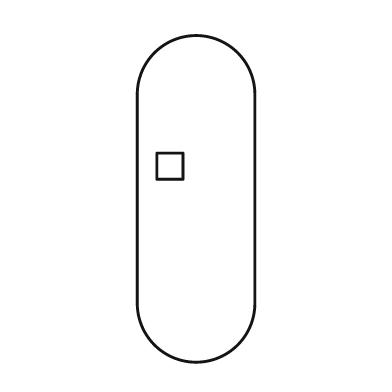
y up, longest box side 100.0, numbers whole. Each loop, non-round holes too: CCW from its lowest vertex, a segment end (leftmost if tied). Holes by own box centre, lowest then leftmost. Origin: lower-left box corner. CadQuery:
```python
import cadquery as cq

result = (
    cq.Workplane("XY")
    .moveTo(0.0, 18.0)
    .threePointArc((18.0, 0.0), (36.0, 18.0))
    .lineTo(36.0, 82.0)
    .threePointArc((18.0, 100.0), (0.0, 82.0))
    .close()
    .moveTo(6.0, 56.0)
    .lineTo(14.0, 56.0)
    .lineTo(14.0, 64.0)
    .lineTo(6.0, 64.0)
    .close()
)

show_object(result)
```